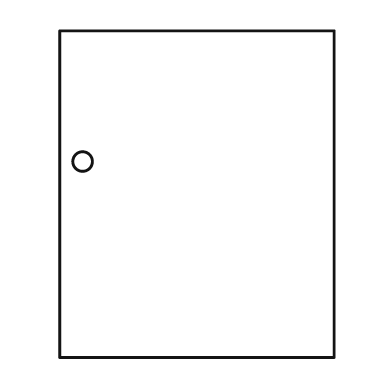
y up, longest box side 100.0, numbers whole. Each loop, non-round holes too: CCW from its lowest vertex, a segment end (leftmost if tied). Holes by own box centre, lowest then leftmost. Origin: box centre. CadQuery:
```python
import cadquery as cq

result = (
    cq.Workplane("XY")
    .moveTo(-42.0, -50.0)
    .lineTo(42.0, -50.0)
    .lineTo(42.0, 50.0)
    .lineTo(-42.0, 50.0)
    .close()
    .moveTo(-35.0, 10.0)
    .circle(3.0)
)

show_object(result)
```